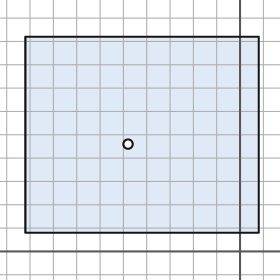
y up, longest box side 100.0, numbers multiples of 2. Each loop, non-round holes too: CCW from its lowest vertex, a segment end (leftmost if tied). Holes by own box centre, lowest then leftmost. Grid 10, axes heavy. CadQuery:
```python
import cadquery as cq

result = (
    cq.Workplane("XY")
    .moveTo(-92.0, 8.0)
    .lineTo(8.0, 8.0)
    .lineTo(8.0, 92.0)
    .lineTo(-92.0, 92.0)
    .close()
    .moveTo(-48.0, 46.0)
    .circle(2.0)
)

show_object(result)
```